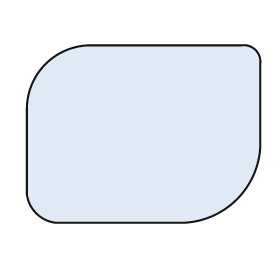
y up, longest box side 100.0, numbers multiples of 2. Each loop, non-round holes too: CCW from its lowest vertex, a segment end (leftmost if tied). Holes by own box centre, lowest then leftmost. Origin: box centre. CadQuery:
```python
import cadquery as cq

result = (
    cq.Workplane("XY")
    .moveTo(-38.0, -38.0)
    .lineTo(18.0, -38.0)
    .threePointArc((40.0, -28.0), (50.0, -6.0))
    .lineTo(50.0, 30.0)
    .threePointArc((48.0, 36.0), (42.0, 38.0))
    .lineTo(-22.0, 38.0)
    .threePointArc((-42.0, 30.0), (-50.0, 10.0))
    .lineTo(-50.0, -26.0)
    .threePointArc((-46.0, -34.0), (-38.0, -38.0))
    .close()
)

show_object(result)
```